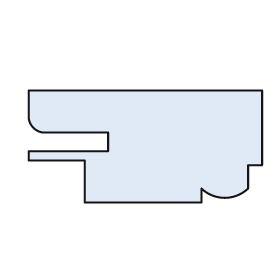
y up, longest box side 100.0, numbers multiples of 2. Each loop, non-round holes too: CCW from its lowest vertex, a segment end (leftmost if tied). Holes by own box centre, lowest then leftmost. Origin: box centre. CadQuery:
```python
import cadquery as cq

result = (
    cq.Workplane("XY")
    .moveTo(-26.0, -24.0)
    .lineTo(24.0, -24.0)
    .lineTo(24.0, -18.0)
    .threePointArc((34.0, -22.0), (44.0, -18.0))
    .lineTo(44.0, -8.0)
    .lineTo(50.0, -8.0)
    .lineTo(50.0, 24.0)
    .lineTo(-50.0, 24.0)
    .lineTo(-50.0, 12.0)
    .threePointArc((-48.0, 8.0), (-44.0, 6.0))
    .lineTo(-16.0, 6.0)
    .lineTo(-16.0, -2.0)
    .lineTo(-50.0, -2.0)
    .lineTo(-50.0, -6.0)
    .lineTo(-26.0, -6.0)
    .close()
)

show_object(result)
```